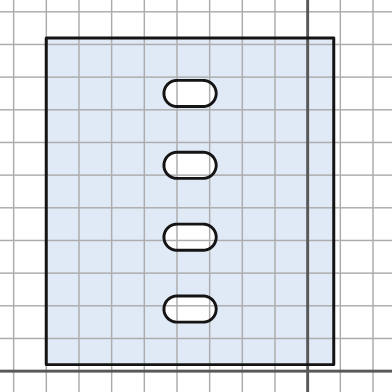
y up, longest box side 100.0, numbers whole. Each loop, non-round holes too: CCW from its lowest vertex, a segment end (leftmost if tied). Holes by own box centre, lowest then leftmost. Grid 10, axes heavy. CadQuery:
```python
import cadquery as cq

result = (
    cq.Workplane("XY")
    .moveTo(-80.0, 2.0)
    .lineTo(8.0, 2.0)
    .lineTo(8.0, 102.0)
    .lineTo(-80.0, 102.0)
    .close()
    .moveTo(-40.0, 15.0)
    .lineTo(-32.0, 15.0)
    .threePointArc((-28.0, 19.0), (-32.0, 23.0))
    .lineTo(-40.0, 23.0)
    .threePointArc((-44.0, 19.0), (-40.0, 15.0))
    .close()
    .moveTo(-40.0, 37.0)
    .lineTo(-32.0, 37.0)
    .threePointArc((-28.0, 41.0), (-32.0, 45.0))
    .lineTo(-40.0, 45.0)
    .threePointArc((-44.0, 41.0), (-40.0, 37.0))
    .close()
    .moveTo(-40.0, 59.0)
    .lineTo(-32.0, 59.0)
    .threePointArc((-28.0, 63.0), (-32.0, 67.0))
    .lineTo(-40.0, 67.0)
    .threePointArc((-44.0, 63.0), (-40.0, 59.0))
    .close()
    .moveTo(-40.0, 81.0)
    .lineTo(-32.0, 81.0)
    .threePointArc((-28.0, 85.0), (-32.0, 89.0))
    .lineTo(-40.0, 89.0)
    .threePointArc((-44.0, 85.0), (-40.0, 81.0))
    .close()
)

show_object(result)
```